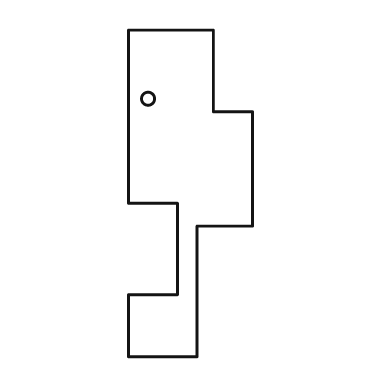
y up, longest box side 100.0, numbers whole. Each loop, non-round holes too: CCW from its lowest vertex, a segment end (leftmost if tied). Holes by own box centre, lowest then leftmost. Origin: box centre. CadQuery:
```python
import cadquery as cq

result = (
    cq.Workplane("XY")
    .moveTo(-19.0, -50.0)
    .lineTo(2.0, -50.0)
    .lineTo(2.0, -10.0)
    .lineTo(19.0, -10.0)
    .lineTo(19.0, 25.0)
    .lineTo(7.0, 25.0)
    .lineTo(7.0, 50.0)
    .lineTo(-19.0, 50.0)
    .lineTo(-19.0, -3.0)
    .lineTo(-4.0, -3.0)
    .lineTo(-4.0, -31.0)
    .lineTo(-19.0, -31.0)
    .close()
    .moveTo(-13.0, 29.0)
    .circle(2.0)
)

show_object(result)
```